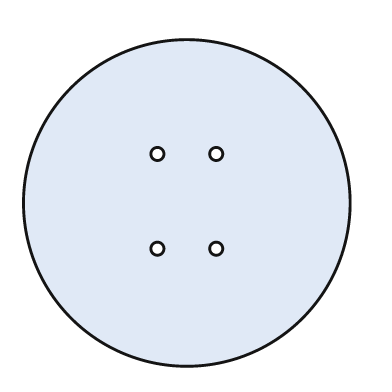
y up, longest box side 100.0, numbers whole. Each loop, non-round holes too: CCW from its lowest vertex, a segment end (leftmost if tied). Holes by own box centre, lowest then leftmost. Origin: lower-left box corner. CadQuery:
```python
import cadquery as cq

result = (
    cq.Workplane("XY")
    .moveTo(50.0, 50.0)
    .circle(50.0)
    .moveTo(41.0, 36.0)
    .circle(2.0)
    .moveTo(59.0, 36.0)
    .circle(2.0)
    .moveTo(41.0, 65.0)
    .circle(2.0)
    .moveTo(59.0, 65.0)
    .circle(2.0)
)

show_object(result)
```